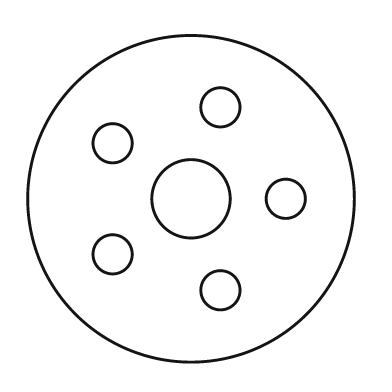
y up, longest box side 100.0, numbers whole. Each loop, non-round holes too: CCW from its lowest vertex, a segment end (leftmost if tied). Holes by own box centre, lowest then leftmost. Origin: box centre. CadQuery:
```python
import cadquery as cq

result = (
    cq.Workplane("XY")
    .moveTo(0.0, 0.0)
    .circle(50.0)
    .moveTo(9.0, -28.0)
    .circle(6.0)
    .moveTo(-24.0, -17.0)
    .circle(6.0)
    .moveTo(0.0, 0.0)
    .circle(12.0)
    .moveTo(29.0, 0.0)
    .circle(6.0)
    .moveTo(-24.0, 17.0)
    .circle(6.0)
    .moveTo(9.0, 28.0)
    .circle(6.0)
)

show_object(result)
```